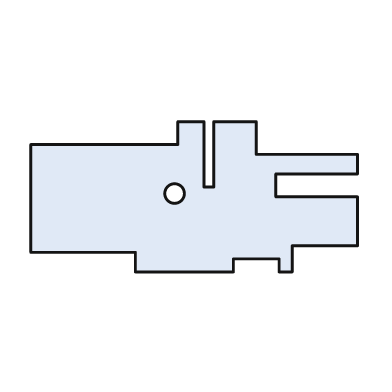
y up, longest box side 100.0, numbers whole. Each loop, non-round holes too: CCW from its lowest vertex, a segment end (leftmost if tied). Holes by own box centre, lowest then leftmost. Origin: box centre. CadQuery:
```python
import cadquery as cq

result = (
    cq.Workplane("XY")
    .moveTo(-18.0, -23.0)
    .lineTo(12.0, -23.0)
    .lineTo(12.0, -19.0)
    .lineTo(26.0, -19.0)
    .lineTo(26.0, -23.0)
    .lineTo(30.0, -23.0)
    .lineTo(30.0, -15.0)
    .lineTo(50.0, -15.0)
    .lineTo(50.0, 0.0)
    .lineTo(25.0, 0.0)
    .lineTo(25.0, 7.0)
    .lineTo(50.0, 7.0)
    .lineTo(50.0, 13.0)
    .lineTo(19.0, 13.0)
    .lineTo(19.0, 23.0)
    .lineTo(6.0, 23.0)
    .lineTo(6.0, 3.0)
    .lineTo(3.0, 3.0)
    .lineTo(3.0, 23.0)
    .lineTo(-5.0, 23.0)
    .lineTo(-5.0, 16.0)
    .lineTo(-50.0, 16.0)
    .lineTo(-50.0, -17.0)
    .lineTo(-18.0, -17.0)
    .close()
    .moveTo(-6.0, 1.0)
    .circle(3.0)
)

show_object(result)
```